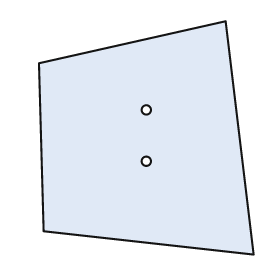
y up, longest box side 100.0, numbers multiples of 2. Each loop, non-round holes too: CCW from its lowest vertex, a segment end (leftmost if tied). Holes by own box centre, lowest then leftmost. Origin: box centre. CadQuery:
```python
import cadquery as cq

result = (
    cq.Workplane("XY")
    .moveTo(46.0, -50.0)
    .lineTo(34.0, 50.0)
    .lineTo(-46.0, 32.0)
    .lineTo(-44.0, -40.0)
    .close()
    .moveTo(0.0, -10.0)
    .circle(2.0)
    .moveTo(0.0, 12.0)
    .circle(2.0)
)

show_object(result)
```